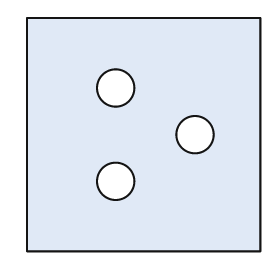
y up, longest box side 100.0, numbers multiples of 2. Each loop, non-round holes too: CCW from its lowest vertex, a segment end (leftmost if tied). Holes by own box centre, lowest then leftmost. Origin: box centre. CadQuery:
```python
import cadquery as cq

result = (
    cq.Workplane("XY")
    .moveTo(-50.0, -50.0)
    .lineTo(50.0, -50.0)
    .lineTo(50.0, 50.0)
    .lineTo(-50.0, 50.0)
    .close()
    .moveTo(-12.0, -20.0)
    .circle(8.0)
    .moveTo(22.0, 0.0)
    .circle(8.0)
    .moveTo(-12.0, 20.0)
    .circle(8.0)
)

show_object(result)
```